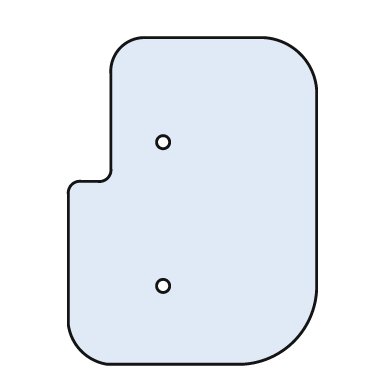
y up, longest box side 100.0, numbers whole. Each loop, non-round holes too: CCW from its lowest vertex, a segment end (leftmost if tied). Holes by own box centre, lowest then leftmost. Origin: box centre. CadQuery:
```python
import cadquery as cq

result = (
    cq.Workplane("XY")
    .moveTo(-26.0, -50.0)
    .lineTo(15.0, -50.0)
    .threePointArc((31.0, -43.0), (38.0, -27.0))
    .lineTo(38.0, 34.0)
    .threePointArc((33.0, 45.0), (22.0, 50.0))
    .lineTo(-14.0, 50.0)
    .threePointArc((-22.0, 47.0), (-25.0, 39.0))
    .lineTo(-25.0, 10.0)
    .threePointArc((-26.0, 7.0), (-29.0, 6.0))
    .lineTo(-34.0, 6.0)
    .threePointArc((-37.0, 5.0), (-38.0, 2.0))
    .lineTo(-38.0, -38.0)
    .threePointArc((-34.0, -46.0), (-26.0, -50.0))
    .close()
    .moveTo(-9.0, -26.0)
    .circle(2.0)
    .moveTo(-9.0, 18.0)
    .circle(2.0)
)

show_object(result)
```